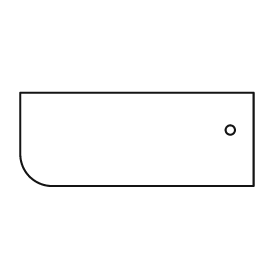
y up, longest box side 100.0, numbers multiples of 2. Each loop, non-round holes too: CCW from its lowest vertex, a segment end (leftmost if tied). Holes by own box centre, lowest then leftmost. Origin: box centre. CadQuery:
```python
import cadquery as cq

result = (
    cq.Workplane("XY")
    .moveTo(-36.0, -20.0)
    .lineTo(50.0, -20.0)
    .lineTo(50.0, 20.0)
    .lineTo(-50.0, 20.0)
    .lineTo(-50.0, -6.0)
    .threePointArc((-46.0, -16.0), (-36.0, -20.0))
    .close()
    .moveTo(40.0, 4.0)
    .circle(2.0)
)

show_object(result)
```